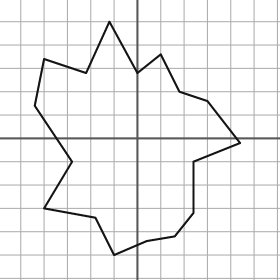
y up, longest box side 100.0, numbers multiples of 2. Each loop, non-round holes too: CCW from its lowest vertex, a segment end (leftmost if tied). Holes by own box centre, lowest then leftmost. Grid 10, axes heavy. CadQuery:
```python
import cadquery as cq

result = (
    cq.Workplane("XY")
    .moveTo(-10.0, -50.0)
    .lineTo(4.0, -44.0)
    .lineTo(16.0, -42.0)
    .lineTo(24.0, -32.0)
    .lineTo(24.0, -10.0)
    .lineTo(44.0, -2.0)
    .lineTo(30.0, 16.0)
    .lineTo(18.0, 20.0)
    .lineTo(10.0, 36.0)
    .lineTo(0.0, 28.0)
    .lineTo(-12.0, 50.0)
    .lineTo(-22.0, 28.0)
    .lineTo(-40.0, 34.0)
    .lineTo(-44.0, 14.0)
    .lineTo(-28.0, -10.0)
    .lineTo(-40.0, -30.0)
    .lineTo(-18.0, -34.0)
    .close()
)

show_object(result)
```